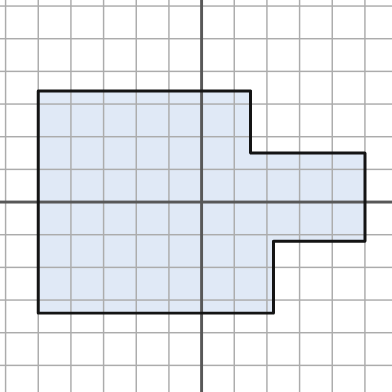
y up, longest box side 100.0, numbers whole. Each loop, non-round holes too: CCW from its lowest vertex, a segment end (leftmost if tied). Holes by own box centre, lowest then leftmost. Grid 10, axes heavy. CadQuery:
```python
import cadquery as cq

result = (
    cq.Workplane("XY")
    .moveTo(-50.0, -34.0)
    .lineTo(22.0, -34.0)
    .lineTo(22.0, -12.0)
    .lineTo(50.0, -12.0)
    .lineTo(50.0, 15.0)
    .lineTo(15.0, 15.0)
    .lineTo(15.0, 34.0)
    .lineTo(-50.0, 34.0)
    .close()
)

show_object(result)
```